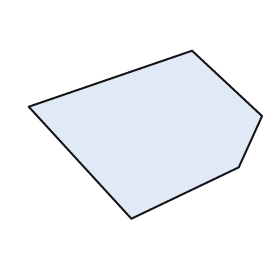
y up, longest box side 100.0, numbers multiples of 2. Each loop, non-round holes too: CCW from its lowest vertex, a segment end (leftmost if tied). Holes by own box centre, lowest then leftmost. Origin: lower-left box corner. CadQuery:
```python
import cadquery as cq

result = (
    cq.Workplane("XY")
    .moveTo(44.0, 0.0)
    .lineTo(90.0, 22.0)
    .lineTo(100.0, 44.0)
    .lineTo(70.0, 72.0)
    .lineTo(0.0, 48.0)
    .close()
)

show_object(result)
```